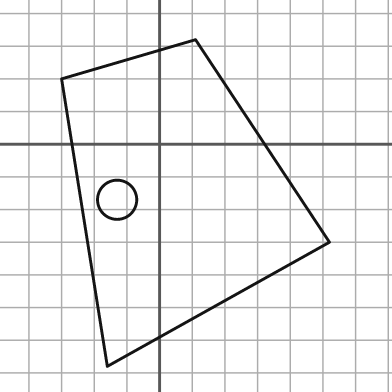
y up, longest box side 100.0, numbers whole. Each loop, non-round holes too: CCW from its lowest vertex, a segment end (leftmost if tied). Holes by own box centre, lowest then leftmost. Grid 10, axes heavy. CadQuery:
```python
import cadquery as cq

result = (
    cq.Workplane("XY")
    .moveTo(-16.0, -68.0)
    .lineTo(52.0, -30.0)
    .lineTo(11.0, 32.0)
    .lineTo(-30.0, 20.0)
    .close()
    .moveTo(-13.0, -17.0)
    .circle(6.0)
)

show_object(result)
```